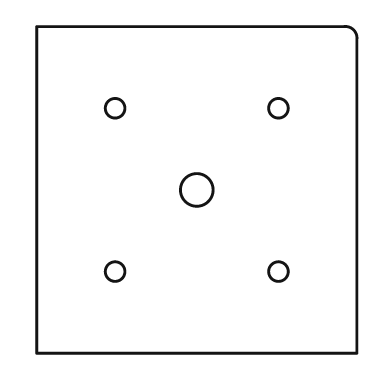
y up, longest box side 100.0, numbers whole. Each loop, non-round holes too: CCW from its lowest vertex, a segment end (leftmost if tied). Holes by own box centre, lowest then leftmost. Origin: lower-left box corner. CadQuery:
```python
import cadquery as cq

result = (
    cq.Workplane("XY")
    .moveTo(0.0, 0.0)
    .lineTo(98.0, 0.0)
    .lineTo(98.0, 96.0)
    .threePointArc((97.0, 99.0), (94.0, 100.0))
    .lineTo(0.0, 100.0)
    .close()
    .moveTo(24.0, 25.0)
    .circle(3.0)
    .moveTo(74.0, 25.0)
    .circle(3.0)
    .moveTo(49.0, 50.0)
    .circle(5.0)
    .moveTo(24.0, 75.0)
    .circle(3.0)
    .moveTo(74.0, 75.0)
    .circle(3.0)
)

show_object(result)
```